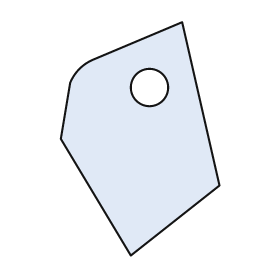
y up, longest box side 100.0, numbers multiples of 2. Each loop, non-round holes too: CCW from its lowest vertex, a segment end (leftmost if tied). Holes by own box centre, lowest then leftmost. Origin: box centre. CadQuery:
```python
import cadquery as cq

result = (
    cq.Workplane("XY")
    .moveTo(-4.0, -50.0)
    .lineTo(34.0, -20.0)
    .lineTo(18.0, 50.0)
    .lineTo(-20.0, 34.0)
    .threePointArc((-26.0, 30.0), (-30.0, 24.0))
    .lineTo(-34.0, 0.0)
    .close()
    .moveTo(4.0, 22.0)
    .circle(8.0)
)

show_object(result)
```